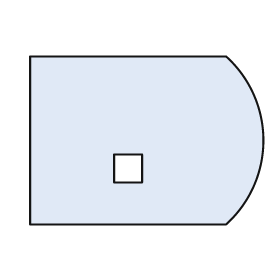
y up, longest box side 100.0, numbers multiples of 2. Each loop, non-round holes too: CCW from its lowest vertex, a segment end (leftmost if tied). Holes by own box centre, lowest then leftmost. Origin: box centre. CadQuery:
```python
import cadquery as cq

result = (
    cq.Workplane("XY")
    .moveTo(-50.0, -36.0)
    .lineTo(34.0, -36.0)
    .threePointArc((50.0, 0.0), (34.0, 36.0))
    .lineTo(-50.0, 36.0)
    .close()
    .moveTo(-14.0, -18.0)
    .lineTo(-2.0, -18.0)
    .lineTo(-2.0, -6.0)
    .lineTo(-14.0, -6.0)
    .close()
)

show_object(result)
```